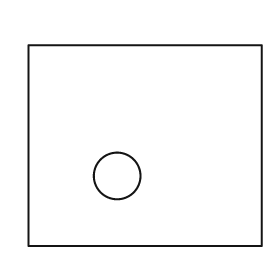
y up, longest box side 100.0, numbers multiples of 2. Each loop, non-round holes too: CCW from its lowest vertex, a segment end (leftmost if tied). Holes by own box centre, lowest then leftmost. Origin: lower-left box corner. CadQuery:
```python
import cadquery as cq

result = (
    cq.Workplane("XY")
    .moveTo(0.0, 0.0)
    .lineTo(100.0, 0.0)
    .lineTo(100.0, 86.0)
    .lineTo(0.0, 86.0)
    .close()
    .moveTo(38.0, 30.0)
    .circle(10.0)
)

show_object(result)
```